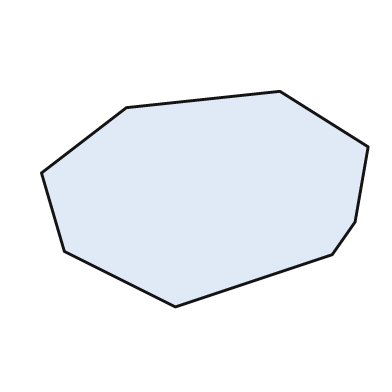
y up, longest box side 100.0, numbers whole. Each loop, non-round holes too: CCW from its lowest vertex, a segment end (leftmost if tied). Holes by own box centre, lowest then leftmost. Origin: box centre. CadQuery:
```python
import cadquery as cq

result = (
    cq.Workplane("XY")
    .moveTo(-9.0, -33.0)
    .lineTo(39.0, -17.0)
    .lineTo(46.0, -7.0)
    .lineTo(50.0, 16.0)
    .lineTo(23.0, 33.0)
    .lineTo(-24.0, 28.0)
    .lineTo(-50.0, 8.0)
    .lineTo(-43.0, -16.0)
    .close()
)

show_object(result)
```